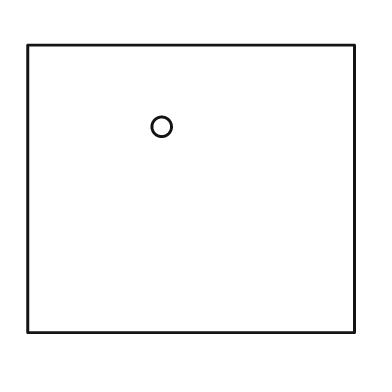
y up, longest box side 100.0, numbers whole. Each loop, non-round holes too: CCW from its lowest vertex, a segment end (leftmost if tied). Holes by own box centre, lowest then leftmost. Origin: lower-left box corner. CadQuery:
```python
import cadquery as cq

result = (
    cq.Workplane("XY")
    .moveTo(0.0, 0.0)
    .lineTo(100.0, 0.0)
    .lineTo(100.0, 88.0)
    .lineTo(0.0, 88.0)
    .close()
    .moveTo(41.0, 63.0)
    .circle(3.0)
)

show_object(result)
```